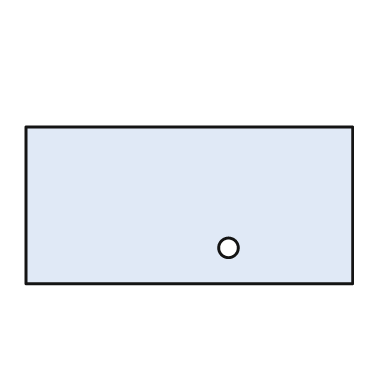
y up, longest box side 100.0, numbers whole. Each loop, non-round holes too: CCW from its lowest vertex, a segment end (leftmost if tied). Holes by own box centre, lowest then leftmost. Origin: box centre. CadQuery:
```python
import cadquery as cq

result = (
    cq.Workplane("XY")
    .moveTo(-50.0, -24.0)
    .lineTo(50.0, -24.0)
    .lineTo(50.0, 24.0)
    .lineTo(-50.0, 24.0)
    .close()
    .moveTo(12.0, -13.0)
    .circle(3.0)
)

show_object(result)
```